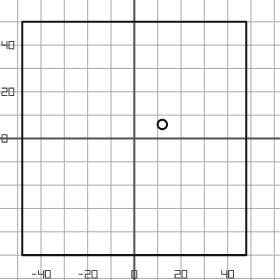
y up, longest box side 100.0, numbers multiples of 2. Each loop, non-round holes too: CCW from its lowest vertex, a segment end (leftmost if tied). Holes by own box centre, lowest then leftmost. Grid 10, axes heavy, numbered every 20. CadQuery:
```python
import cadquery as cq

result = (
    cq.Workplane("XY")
    .moveTo(-48.0, -50.0)
    .lineTo(48.0, -50.0)
    .lineTo(48.0, 50.0)
    .lineTo(-48.0, 50.0)
    .close()
    .moveTo(12.0, 6.0)
    .circle(2.0)
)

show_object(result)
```